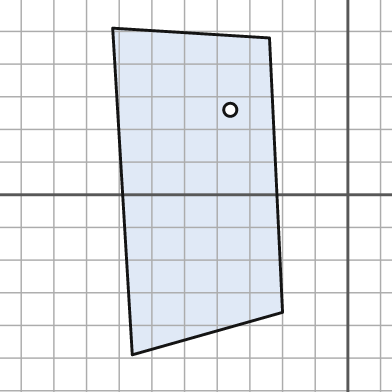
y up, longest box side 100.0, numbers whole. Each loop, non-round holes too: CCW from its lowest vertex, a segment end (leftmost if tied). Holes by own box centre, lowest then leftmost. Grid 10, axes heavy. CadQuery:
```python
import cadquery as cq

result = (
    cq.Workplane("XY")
    .moveTo(-66.0, -49.0)
    .lineTo(-20.0, -36.0)
    .lineTo(-24.0, 48.0)
    .lineTo(-72.0, 51.0)
    .close()
    .moveTo(-36.0, 26.0)
    .circle(2.0)
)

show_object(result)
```